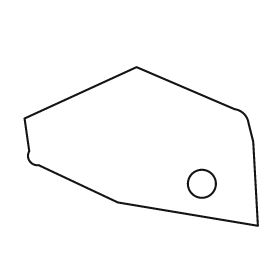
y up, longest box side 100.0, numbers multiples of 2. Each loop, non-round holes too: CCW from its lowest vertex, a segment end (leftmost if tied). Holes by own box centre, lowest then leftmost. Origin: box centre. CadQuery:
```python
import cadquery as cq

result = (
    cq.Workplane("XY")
    .moveTo(50.0, -34.0)
    .lineTo(48.0, 2.0)
    .lineTo(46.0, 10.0)
    .threePointArc((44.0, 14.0), (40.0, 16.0))
    .lineTo(-2.0, 34.0)
    .lineTo(-50.0, 12.0)
    .lineTo(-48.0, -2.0)
    .threePointArc((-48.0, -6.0), (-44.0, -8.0))
    .lineTo(-10.0, -24.0)
    .close()
    .moveTo(26.0, -16.0)
    .circle(6.0)
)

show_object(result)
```